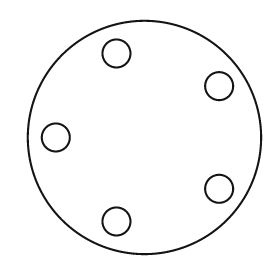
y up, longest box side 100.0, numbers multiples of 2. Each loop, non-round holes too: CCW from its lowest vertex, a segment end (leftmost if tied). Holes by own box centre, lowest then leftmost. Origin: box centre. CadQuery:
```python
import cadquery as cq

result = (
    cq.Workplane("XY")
    .moveTo(0.0, 0.0)
    .circle(50.0)
    .moveTo(-12.0, -36.0)
    .circle(6.0)
    .moveTo(32.0, -22.0)
    .circle(6.0)
    .moveTo(-38.0, 0.0)
    .circle(6.0)
    .moveTo(32.0, 22.0)
    .circle(6.0)
    .moveTo(-12.0, 36.0)
    .circle(6.0)
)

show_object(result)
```